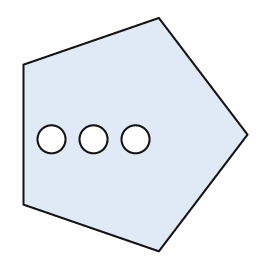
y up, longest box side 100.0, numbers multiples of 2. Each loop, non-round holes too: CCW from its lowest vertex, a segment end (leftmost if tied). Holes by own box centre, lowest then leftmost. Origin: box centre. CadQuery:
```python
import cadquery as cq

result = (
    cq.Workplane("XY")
    .moveTo(10.0, -50.0)
    .lineTo(48.0, 0.0)
    .lineTo(10.0, 50.0)
    .lineTo(-48.0, 30.0)
    .lineTo(-48.0, -30.0)
    .close()
    .moveTo(-36.0, -2.0)
    .circle(6.0)
    .moveTo(-18.0, -2.0)
    .circle(6.0)
    .moveTo(0.0, -2.0)
    .circle(6.0)
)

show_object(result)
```